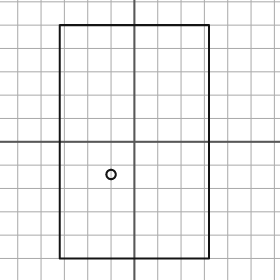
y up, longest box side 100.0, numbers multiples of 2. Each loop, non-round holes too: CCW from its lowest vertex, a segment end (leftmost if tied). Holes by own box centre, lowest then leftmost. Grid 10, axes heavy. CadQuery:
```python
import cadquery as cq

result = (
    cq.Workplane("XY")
    .moveTo(-32.0, -50.0)
    .lineTo(32.0, -50.0)
    .lineTo(32.0, 50.0)
    .lineTo(-32.0, 50.0)
    .close()
    .moveTo(-10.0, -14.0)
    .circle(2.0)
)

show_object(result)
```